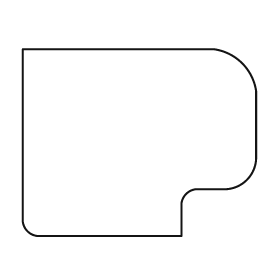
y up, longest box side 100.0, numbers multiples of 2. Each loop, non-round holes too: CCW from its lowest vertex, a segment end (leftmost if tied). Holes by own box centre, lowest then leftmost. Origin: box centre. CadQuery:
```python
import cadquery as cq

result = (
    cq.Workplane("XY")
    .moveTo(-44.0, -40.0)
    .lineTo(18.0, -40.0)
    .lineTo(18.0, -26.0)
    .threePointArc((20.0, -22.0), (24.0, -20.0))
    .lineTo(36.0, -20.0)
    .threePointArc((46.0, -16.0), (50.0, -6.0))
    .lineTo(50.0, 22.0)
    .threePointArc((44.0, 34.0), (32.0, 40.0))
    .lineTo(-50.0, 40.0)
    .lineTo(-50.0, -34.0)
    .threePointArc((-48.0, -38.0), (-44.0, -40.0))
    .close()
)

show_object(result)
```